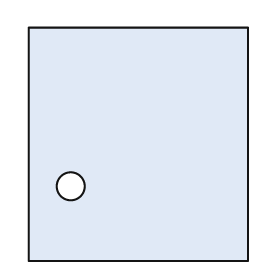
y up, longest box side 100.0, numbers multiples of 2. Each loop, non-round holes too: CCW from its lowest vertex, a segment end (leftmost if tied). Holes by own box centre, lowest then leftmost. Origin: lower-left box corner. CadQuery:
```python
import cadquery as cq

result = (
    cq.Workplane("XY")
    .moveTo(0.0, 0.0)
    .lineTo(94.0, 0.0)
    .lineTo(94.0, 100.0)
    .lineTo(0.0, 100.0)
    .close()
    .moveTo(18.0, 32.0)
    .circle(6.0)
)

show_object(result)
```